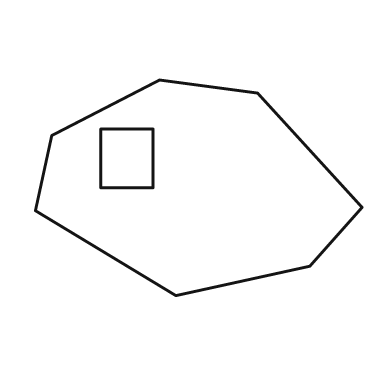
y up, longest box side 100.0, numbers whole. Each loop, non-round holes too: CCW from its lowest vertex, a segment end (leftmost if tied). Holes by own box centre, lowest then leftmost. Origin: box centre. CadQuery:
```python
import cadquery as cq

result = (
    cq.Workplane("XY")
    .moveTo(-7.0, -33.0)
    .lineTo(34.0, -24.0)
    .lineTo(50.0, -6.0)
    .lineTo(18.0, 29.0)
    .lineTo(-12.0, 33.0)
    .lineTo(-45.0, 16.0)
    .lineTo(-50.0, -7.0)
    .close()
    .moveTo(-30.0, 0.0)
    .lineTo(-14.0, 0.0)
    .lineTo(-14.0, 18.0)
    .lineTo(-30.0, 18.0)
    .close()
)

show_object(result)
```